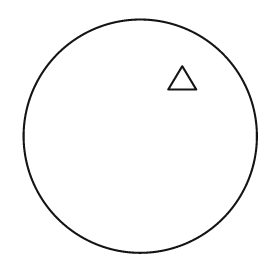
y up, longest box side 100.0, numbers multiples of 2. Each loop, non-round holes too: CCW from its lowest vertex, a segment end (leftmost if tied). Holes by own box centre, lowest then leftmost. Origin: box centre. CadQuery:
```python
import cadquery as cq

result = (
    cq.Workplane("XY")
    .moveTo(0.0, 0.0)
    .circle(50.0)
    .moveTo(12.0, 20.0)
    .lineTo(24.0, 20.0)
    .lineTo(18.0, 30.0)
    .close()
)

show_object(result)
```